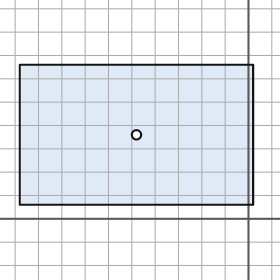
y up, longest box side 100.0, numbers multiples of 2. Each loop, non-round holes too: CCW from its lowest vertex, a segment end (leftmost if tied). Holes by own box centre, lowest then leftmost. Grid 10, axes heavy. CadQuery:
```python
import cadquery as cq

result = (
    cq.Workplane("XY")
    .moveTo(-98.0, 6.0)
    .lineTo(2.0, 6.0)
    .lineTo(2.0, 66.0)
    .lineTo(-98.0, 66.0)
    .close()
    .moveTo(-48.0, 36.0)
    .circle(2.0)
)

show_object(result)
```